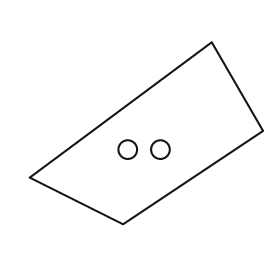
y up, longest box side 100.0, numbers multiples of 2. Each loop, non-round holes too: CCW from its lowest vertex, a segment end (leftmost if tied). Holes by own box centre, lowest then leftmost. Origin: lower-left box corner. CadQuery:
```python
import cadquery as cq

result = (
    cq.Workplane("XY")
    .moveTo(40.0, 0.0)
    .lineTo(100.0, 40.0)
    .lineTo(78.0, 78.0)
    .lineTo(0.0, 20.0)
    .close()
    .moveTo(42.0, 32.0)
    .circle(4.0)
    .moveTo(56.0, 32.0)
    .circle(4.0)
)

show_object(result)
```